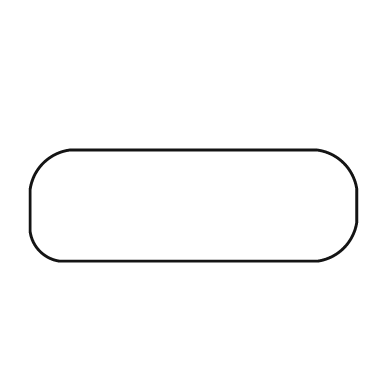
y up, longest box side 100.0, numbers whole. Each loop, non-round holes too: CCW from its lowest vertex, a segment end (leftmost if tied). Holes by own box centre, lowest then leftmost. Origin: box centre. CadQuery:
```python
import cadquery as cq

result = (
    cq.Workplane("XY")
    .moveTo(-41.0, -17.0)
    .lineTo(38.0, -17.0)
    .threePointArc((46.0, -13.0), (50.0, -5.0))
    .lineTo(50.0, 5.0)
    .threePointArc((46.0, 13.0), (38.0, 17.0))
    .lineTo(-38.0, 17.0)
    .threePointArc((-46.0, 13.0), (-50.0, 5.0))
    .lineTo(-50.0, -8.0)
    .threePointArc((-47.0, -14.0), (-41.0, -17.0))
    .close()
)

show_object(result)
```